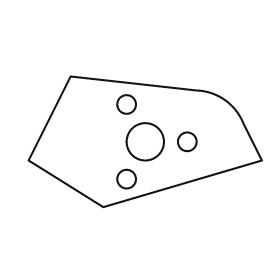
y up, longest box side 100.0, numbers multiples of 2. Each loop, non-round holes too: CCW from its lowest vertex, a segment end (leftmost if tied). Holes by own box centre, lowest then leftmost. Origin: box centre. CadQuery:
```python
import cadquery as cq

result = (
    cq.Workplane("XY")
    .moveTo(-18.0, -28.0)
    .lineTo(50.0, -8.0)
    .lineTo(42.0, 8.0)
    .threePointArc((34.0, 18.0), (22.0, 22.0))
    .lineTo(-32.0, 28.0)
    .lineTo(-50.0, -8.0)
    .close()
    .moveTo(-8.0, -16.0)
    .circle(4.0)
    .moveTo(0.0, 0.0)
    .circle(8.0)
    .moveTo(18.0, 0.0)
    .circle(4.0)
    .moveTo(-8.0, 16.0)
    .circle(4.0)
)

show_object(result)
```